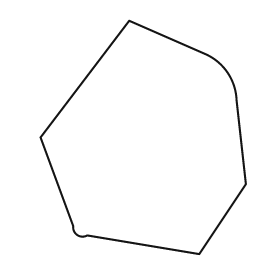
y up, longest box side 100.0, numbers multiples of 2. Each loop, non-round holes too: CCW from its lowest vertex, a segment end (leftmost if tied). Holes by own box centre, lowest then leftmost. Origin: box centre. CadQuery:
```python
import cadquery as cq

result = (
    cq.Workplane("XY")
    .moveTo(24.0, -50.0)
    .lineTo(44.0, -20.0)
    .lineTo(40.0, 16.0)
    .threePointArc((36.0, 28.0), (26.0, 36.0))
    .lineTo(-6.0, 50.0)
    .lineTo(-44.0, 0.0)
    .lineTo(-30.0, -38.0)
    .threePointArc((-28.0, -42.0), (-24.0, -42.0))
    .close()
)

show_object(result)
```